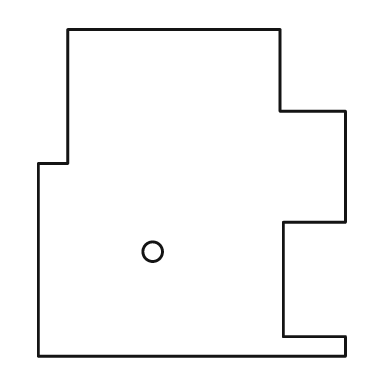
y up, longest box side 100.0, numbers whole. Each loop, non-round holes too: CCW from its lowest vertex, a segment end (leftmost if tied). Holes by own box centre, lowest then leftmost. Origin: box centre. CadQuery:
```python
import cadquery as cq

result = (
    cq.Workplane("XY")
    .moveTo(-47.0, -50.0)
    .lineTo(47.0, -50.0)
    .lineTo(47.0, -44.0)
    .lineTo(28.0, -44.0)
    .lineTo(28.0, -9.0)
    .lineTo(47.0, -9.0)
    .lineTo(47.0, 25.0)
    .lineTo(27.0, 25.0)
    .lineTo(27.0, 50.0)
    .lineTo(-38.0, 50.0)
    .lineTo(-38.0, 9.0)
    .lineTo(-47.0, 9.0)
    .close()
    .moveTo(-12.0, -18.0)
    .circle(3.0)
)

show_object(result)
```